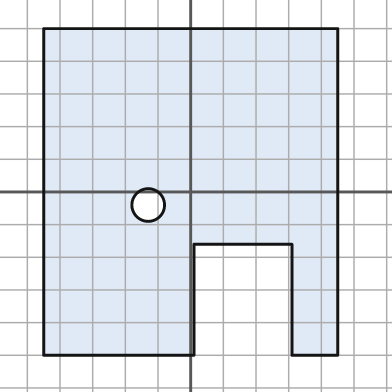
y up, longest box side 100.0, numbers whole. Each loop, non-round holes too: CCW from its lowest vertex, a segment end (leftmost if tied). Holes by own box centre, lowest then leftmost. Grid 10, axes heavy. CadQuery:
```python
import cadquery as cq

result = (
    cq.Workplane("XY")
    .moveTo(-45.0, -50.0)
    .lineTo(1.0, -50.0)
    .lineTo(1.0, -16.0)
    .lineTo(31.0, -16.0)
    .lineTo(31.0, -50.0)
    .lineTo(45.0, -50.0)
    .lineTo(45.0, 50.0)
    .lineTo(-45.0, 50.0)
    .close()
    .moveTo(-13.0, -4.0)
    .circle(5.0)
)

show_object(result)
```